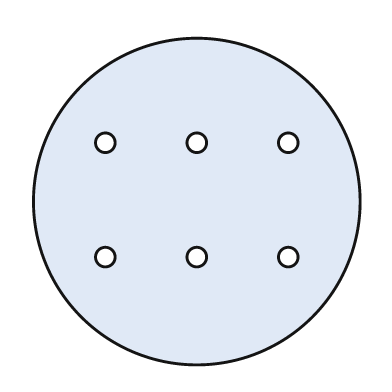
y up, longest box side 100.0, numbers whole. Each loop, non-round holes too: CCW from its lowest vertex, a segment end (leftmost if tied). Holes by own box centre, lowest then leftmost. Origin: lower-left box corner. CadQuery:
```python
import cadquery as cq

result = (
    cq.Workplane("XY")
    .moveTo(50.0, 50.0)
    .circle(50.0)
    .moveTo(22.0, 33.0)
    .circle(3.0)
    .moveTo(50.0, 33.0)
    .circle(3.0)
    .moveTo(78.0, 33.0)
    .circle(3.0)
    .moveTo(22.0, 68.0)
    .circle(3.0)
    .moveTo(50.0, 68.0)
    .circle(3.0)
    .moveTo(78.0, 68.0)
    .circle(3.0)
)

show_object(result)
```